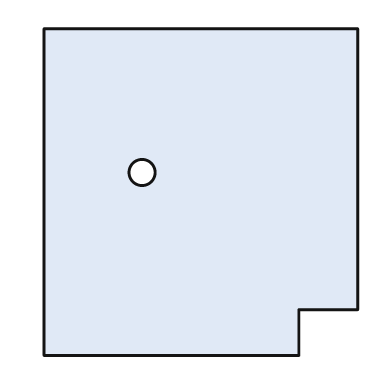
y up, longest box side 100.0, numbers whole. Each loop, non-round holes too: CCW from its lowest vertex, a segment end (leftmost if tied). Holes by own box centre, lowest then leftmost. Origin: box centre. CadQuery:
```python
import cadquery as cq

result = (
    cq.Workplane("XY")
    .moveTo(-48.0, -50.0)
    .lineTo(30.0, -50.0)
    .lineTo(30.0, -36.0)
    .lineTo(48.0, -36.0)
    .lineTo(48.0, 50.0)
    .lineTo(-48.0, 50.0)
    .close()
    .moveTo(-18.0, 6.0)
    .circle(4.0)
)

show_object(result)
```